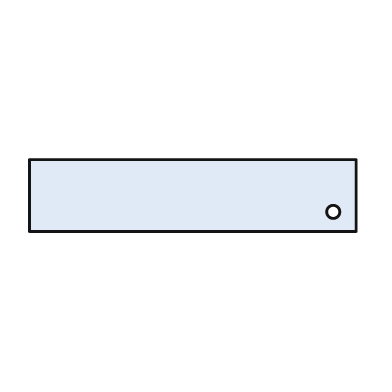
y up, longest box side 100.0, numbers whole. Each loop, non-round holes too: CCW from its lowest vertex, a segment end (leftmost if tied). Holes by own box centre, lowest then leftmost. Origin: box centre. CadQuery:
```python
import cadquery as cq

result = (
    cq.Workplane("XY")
    .moveTo(-50.0, -11.0)
    .lineTo(50.0, -11.0)
    .lineTo(50.0, 11.0)
    .lineTo(-50.0, 11.0)
    .close()
    .moveTo(43.0, -5.0)
    .circle(2.0)
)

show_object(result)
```